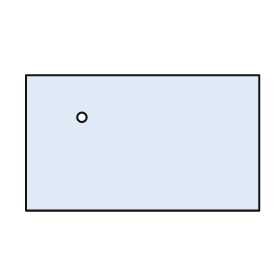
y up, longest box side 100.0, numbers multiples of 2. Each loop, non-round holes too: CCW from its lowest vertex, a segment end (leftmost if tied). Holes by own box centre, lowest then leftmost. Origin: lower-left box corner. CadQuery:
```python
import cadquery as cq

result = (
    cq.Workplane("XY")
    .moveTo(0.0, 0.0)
    .lineTo(100.0, 0.0)
    .lineTo(100.0, 58.0)
    .lineTo(0.0, 58.0)
    .close()
    .moveTo(24.0, 40.0)
    .circle(2.0)
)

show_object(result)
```